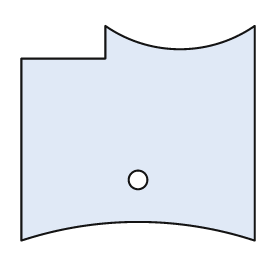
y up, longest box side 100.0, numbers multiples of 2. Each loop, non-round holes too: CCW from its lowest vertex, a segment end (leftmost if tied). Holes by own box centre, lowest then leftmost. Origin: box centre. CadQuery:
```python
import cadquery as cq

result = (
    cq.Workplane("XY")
    .moveTo(-50.0, -46.0)
    .threePointArc((0.0, -38.0), (50.0, -46.0))
    .lineTo(50.0, 46.0)
    .threePointArc((18.0, 36.0), (-14.0, 46.0))
    .lineTo(-14.0, 32.0)
    .lineTo(-50.0, 32.0)
    .close()
    .moveTo(0.0, -20.0)
    .circle(4.0)
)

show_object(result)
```